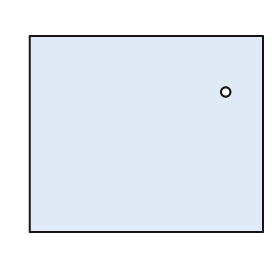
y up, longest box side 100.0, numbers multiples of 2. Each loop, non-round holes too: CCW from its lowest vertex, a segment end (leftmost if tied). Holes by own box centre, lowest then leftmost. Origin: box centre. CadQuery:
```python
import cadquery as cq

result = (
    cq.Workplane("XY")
    .moveTo(-50.0, -42.0)
    .lineTo(50.0, -42.0)
    .lineTo(50.0, 42.0)
    .lineTo(-50.0, 42.0)
    .close()
    .moveTo(34.0, 18.0)
    .circle(2.0)
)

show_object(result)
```